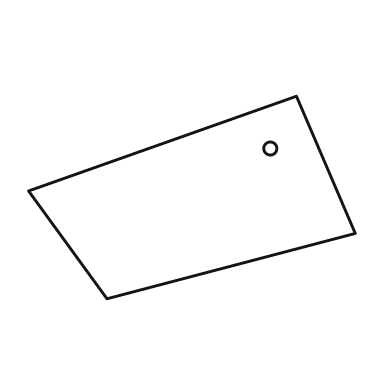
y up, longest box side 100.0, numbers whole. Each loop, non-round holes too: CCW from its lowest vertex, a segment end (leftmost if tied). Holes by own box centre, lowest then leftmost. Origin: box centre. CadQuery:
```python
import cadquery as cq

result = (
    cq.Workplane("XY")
    .moveTo(-26.0, -31.0)
    .lineTo(50.0, -11.0)
    .lineTo(32.0, 31.0)
    .lineTo(-50.0, 2.0)
    .close()
    .moveTo(24.0, 15.0)
    .circle(2.0)
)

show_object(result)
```